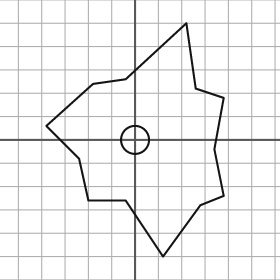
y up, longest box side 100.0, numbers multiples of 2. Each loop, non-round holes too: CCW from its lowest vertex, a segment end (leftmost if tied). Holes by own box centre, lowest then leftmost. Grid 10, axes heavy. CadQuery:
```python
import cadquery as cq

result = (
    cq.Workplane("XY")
    .moveTo(12.0, -50.0)
    .lineTo(28.0, -28.0)
    .lineTo(38.0, -24.0)
    .lineTo(34.0, -4.0)
    .lineTo(38.0, 18.0)
    .lineTo(26.0, 22.0)
    .lineTo(22.0, 50.0)
    .lineTo(-4.0, 26.0)
    .lineTo(-18.0, 24.0)
    .lineTo(-38.0, 6.0)
    .lineTo(-24.0, -8.0)
    .lineTo(-20.0, -26.0)
    .lineTo(-4.0, -26.0)
    .close()
    .moveTo(0.0, 0.0)
    .circle(6.0)
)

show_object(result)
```